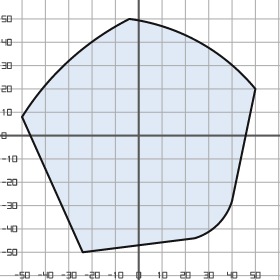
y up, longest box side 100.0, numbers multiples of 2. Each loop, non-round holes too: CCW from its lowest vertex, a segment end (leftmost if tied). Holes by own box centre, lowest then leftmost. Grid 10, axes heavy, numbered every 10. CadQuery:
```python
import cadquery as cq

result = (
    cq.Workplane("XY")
    .moveTo(-24.0, -50.0)
    .lineTo(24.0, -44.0)
    .threePointArc((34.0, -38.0), (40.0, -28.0))
    .lineTo(50.0, 20.0)
    .threePointArc((26.0, 40.0), (-4.0, 50.0))
    .threePointArc((-30.0, 32.0), (-50.0, 8.0))
    .close()
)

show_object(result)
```